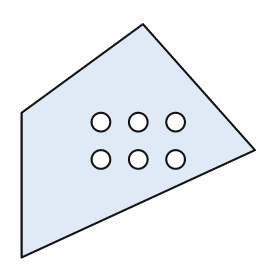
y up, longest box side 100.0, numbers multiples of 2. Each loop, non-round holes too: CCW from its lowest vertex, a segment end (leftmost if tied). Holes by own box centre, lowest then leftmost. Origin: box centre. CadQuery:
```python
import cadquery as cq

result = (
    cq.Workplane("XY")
    .moveTo(-50.0, -50.0)
    .lineTo(50.0, -4.0)
    .lineTo(2.0, 50.0)
    .lineTo(-50.0, 12.0)
    .close()
    .moveTo(-16.0, -8.0)
    .circle(4.0)
    .moveTo(0.0, -8.0)
    .circle(4.0)
    .moveTo(16.0, -8.0)
    .circle(4.0)
    .moveTo(-16.0, 8.0)
    .circle(4.0)
    .moveTo(0.0, 8.0)
    .circle(4.0)
    .moveTo(16.0, 8.0)
    .circle(4.0)
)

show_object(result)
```